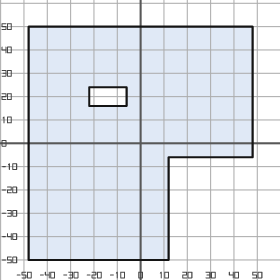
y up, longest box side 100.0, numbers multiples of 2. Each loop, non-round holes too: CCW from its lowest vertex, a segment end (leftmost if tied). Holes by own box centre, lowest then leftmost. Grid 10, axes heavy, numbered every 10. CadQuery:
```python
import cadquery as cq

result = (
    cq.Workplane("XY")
    .moveTo(-48.0, -50.0)
    .lineTo(12.0, -50.0)
    .lineTo(12.0, -6.0)
    .lineTo(48.0, -6.0)
    .lineTo(48.0, 50.0)
    .lineTo(-48.0, 50.0)
    .close()
    .moveTo(-22.0, 16.0)
    .lineTo(-6.0, 16.0)
    .lineTo(-6.0, 24.0)
    .lineTo(-22.0, 24.0)
    .close()
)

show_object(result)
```